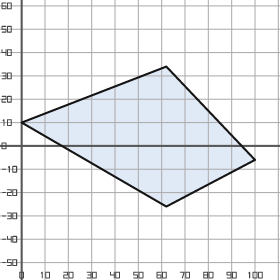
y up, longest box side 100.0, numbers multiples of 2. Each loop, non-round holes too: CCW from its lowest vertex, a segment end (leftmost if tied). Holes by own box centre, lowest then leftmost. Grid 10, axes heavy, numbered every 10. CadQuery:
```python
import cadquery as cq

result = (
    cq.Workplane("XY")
    .moveTo(62.0, -26.0)
    .lineTo(100.0, -6.0)
    .lineTo(62.0, 34.0)
    .lineTo(0.0, 10.0)
    .close()
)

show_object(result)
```